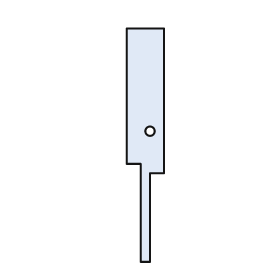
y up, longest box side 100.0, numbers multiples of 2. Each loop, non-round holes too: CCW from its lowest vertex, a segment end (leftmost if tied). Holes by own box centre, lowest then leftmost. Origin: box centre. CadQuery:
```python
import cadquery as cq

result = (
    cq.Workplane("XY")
    .moveTo(-2.0, -50.0)
    .lineTo(2.0, -50.0)
    .lineTo(2.0, -12.0)
    .lineTo(8.0, -12.0)
    .lineTo(8.0, 50.0)
    .lineTo(-8.0, 50.0)
    .lineTo(-8.0, -8.0)
    .lineTo(-2.0, -8.0)
    .close()
    .moveTo(2.0, 6.0)
    .circle(2.0)
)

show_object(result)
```